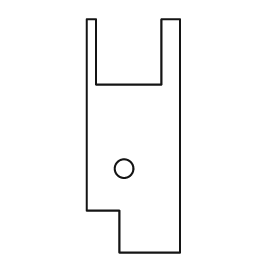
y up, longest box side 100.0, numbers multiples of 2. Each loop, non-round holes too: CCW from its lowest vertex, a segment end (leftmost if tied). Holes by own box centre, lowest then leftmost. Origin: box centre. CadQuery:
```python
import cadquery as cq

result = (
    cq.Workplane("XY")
    .moveTo(-6.0, -50.0)
    .lineTo(20.0, -50.0)
    .lineTo(20.0, 50.0)
    .lineTo(12.0, 50.0)
    .lineTo(12.0, 22.0)
    .lineTo(-16.0, 22.0)
    .lineTo(-16.0, 50.0)
    .lineTo(-20.0, 50.0)
    .lineTo(-20.0, -32.0)
    .lineTo(-6.0, -32.0)
    .close()
    .moveTo(-4.0, -14.0)
    .circle(4.0)
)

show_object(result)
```